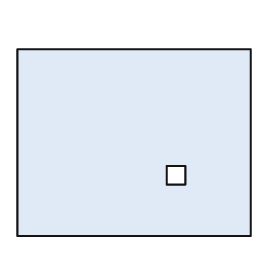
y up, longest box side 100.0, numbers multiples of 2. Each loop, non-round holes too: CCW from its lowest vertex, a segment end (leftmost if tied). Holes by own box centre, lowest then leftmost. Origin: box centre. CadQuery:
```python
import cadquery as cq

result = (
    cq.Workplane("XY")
    .moveTo(-50.0, -40.0)
    .lineTo(50.0, -40.0)
    .lineTo(50.0, 40.0)
    .lineTo(-50.0, 40.0)
    .close()
    .moveTo(14.0, -18.0)
    .lineTo(22.0, -18.0)
    .lineTo(22.0, -10.0)
    .lineTo(14.0, -10.0)
    .close()
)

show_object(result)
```